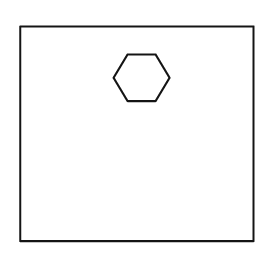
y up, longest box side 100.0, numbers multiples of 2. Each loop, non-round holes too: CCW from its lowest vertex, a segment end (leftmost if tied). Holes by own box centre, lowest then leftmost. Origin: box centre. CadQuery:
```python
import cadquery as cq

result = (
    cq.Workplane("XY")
    .moveTo(-50.0, -46.0)
    .lineTo(50.0, -46.0)
    .lineTo(50.0, 46.0)
    .lineTo(-50.0, 46.0)
    .close()
    .moveTo(-4.0, 14.0)
    .lineTo(8.0, 14.0)
    .lineTo(14.0, 24.0)
    .lineTo(8.0, 34.0)
    .lineTo(-4.0, 34.0)
    .lineTo(-10.0, 24.0)
    .close()
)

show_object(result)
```